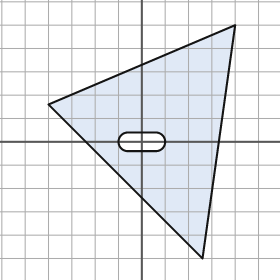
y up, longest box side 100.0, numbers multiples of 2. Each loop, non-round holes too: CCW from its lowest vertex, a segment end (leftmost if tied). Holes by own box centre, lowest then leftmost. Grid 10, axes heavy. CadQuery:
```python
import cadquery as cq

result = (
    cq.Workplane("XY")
    .moveTo(26.0, -50.0)
    .lineTo(40.0, 50.0)
    .lineTo(-40.0, 16.0)
    .close()
    .moveTo(-6.0, -4.0)
    .lineTo(6.0, -4.0)
    .threePointArc((10.0, 0.0), (6.0, 4.0))
    .lineTo(-6.0, 4.0)
    .threePointArc((-10.0, 0.0), (-6.0, -4.0))
    .close()
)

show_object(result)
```